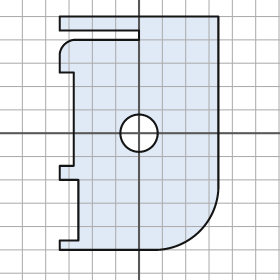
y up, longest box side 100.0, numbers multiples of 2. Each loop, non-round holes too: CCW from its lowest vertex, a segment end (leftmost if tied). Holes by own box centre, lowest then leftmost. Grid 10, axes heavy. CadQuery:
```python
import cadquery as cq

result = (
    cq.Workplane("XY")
    .moveTo(-34.0, -50.0)
    .lineTo(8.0, -50.0)
    .threePointArc((26.0, -42.0), (34.0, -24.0))
    .lineTo(34.0, 50.0)
    .lineTo(-34.0, 50.0)
    .lineTo(-34.0, 44.0)
    .lineTo(0.0, 44.0)
    .lineTo(0.0, 40.0)
    .lineTo(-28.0, 40.0)
    .threePointArc((-32.0, 38.0), (-34.0, 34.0))
    .lineTo(-34.0, 26.0)
    .lineTo(-28.0, 26.0)
    .lineTo(-28.0, -14.0)
    .lineTo(-34.0, -14.0)
    .lineTo(-34.0, -20.0)
    .lineTo(-26.0, -20.0)
    .lineTo(-26.0, -46.0)
    .lineTo(-34.0, -46.0)
    .close()
    .moveTo(0.0, 0.0)
    .circle(8.0)
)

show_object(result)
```